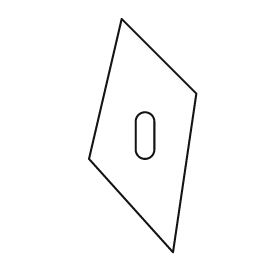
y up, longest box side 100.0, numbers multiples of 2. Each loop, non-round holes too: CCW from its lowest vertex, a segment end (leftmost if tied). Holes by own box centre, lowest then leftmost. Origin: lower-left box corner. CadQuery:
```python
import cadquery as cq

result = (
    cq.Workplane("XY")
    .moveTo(36.0, 0.0)
    .lineTo(46.0, 68.0)
    .lineTo(14.0, 100.0)
    .lineTo(0.0, 40.0)
    .close()
    .moveTo(20.0, 44.0)
    .threePointArc((24.0, 40.0), (28.0, 44.0))
    .lineTo(28.0, 56.0)
    .threePointArc((24.0, 60.0), (20.0, 56.0))
    .close()
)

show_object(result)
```